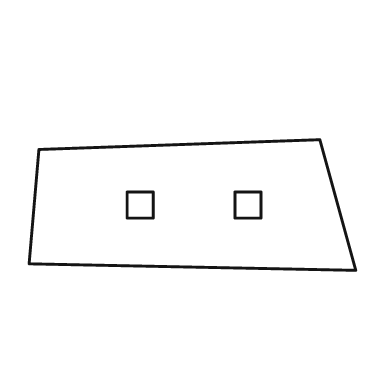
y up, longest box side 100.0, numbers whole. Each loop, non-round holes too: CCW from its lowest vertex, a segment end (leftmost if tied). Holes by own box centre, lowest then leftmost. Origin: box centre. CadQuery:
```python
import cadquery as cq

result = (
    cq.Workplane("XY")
    .moveTo(50.0, -20.0)
    .lineTo(39.0, 20.0)
    .lineTo(-47.0, 17.0)
    .lineTo(-50.0, -18.0)
    .close()
    .moveTo(-20.0, -4.0)
    .lineTo(-12.0, -4.0)
    .lineTo(-12.0, 4.0)
    .lineTo(-20.0, 4.0)
    .close()
    .moveTo(13.0, -4.0)
    .lineTo(21.0, -4.0)
    .lineTo(21.0, 4.0)
    .lineTo(13.0, 4.0)
    .close()
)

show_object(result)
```